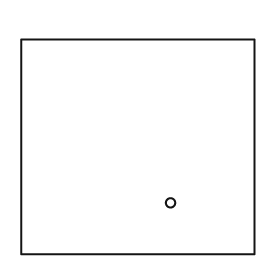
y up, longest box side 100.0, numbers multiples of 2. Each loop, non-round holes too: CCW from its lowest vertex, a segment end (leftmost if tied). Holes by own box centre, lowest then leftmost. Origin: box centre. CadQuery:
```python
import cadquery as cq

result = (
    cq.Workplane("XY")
    .moveTo(-50.0, -46.0)
    .lineTo(50.0, -46.0)
    .lineTo(50.0, 46.0)
    .lineTo(-50.0, 46.0)
    .close()
    .moveTo(14.0, -24.0)
    .circle(2.0)
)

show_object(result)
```